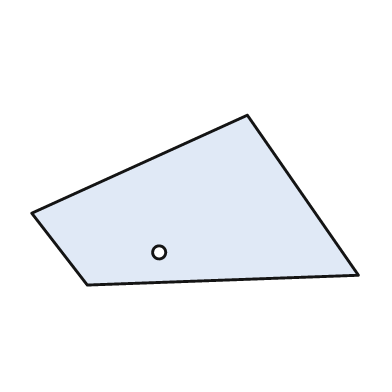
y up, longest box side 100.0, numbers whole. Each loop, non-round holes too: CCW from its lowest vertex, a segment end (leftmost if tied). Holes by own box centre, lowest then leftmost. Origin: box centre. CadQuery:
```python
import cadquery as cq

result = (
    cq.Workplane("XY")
    .moveTo(-33.0, -26.0)
    .lineTo(50.0, -23.0)
    .lineTo(16.0, 26.0)
    .lineTo(-50.0, -4.0)
    .close()
    .moveTo(-11.0, -16.0)
    .circle(2.0)
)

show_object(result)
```